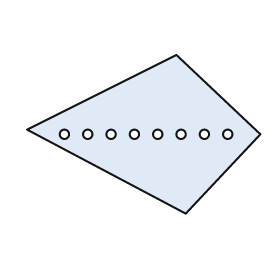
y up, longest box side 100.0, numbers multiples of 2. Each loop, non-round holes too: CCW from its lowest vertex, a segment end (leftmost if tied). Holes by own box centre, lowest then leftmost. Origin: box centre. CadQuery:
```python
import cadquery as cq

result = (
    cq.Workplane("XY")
    .moveTo(18.0, -34.0)
    .lineTo(50.0, 0.0)
    .lineTo(14.0, 34.0)
    .lineTo(-50.0, 2.0)
    .close()
    .moveTo(-34.0, 0.0)
    .circle(2.0)
    .moveTo(-24.0, 0.0)
    .circle(2.0)
    .moveTo(-14.0, 0.0)
    .circle(2.0)
    .moveTo(-4.0, 0.0)
    .circle(2.0)
    .moveTo(6.0, 0.0)
    .circle(2.0)
    .moveTo(16.0, 0.0)
    .circle(2.0)
    .moveTo(26.0, 0.0)
    .circle(2.0)
    .moveTo(36.0, 0.0)
    .circle(2.0)
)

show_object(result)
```